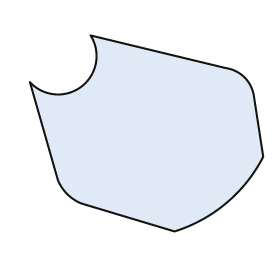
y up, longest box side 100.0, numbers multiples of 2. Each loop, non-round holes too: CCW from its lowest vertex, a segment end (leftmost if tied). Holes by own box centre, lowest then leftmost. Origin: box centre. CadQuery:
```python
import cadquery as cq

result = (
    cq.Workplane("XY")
    .moveTo(12.0, -42.0)
    .threePointArc((34.0, -30.0), (50.0, -10.0))
    .lineTo(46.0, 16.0)
    .threePointArc((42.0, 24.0), (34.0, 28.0))
    .lineTo(-24.0, 42.0)
    .threePointArc((-28.0, 20.0), (-50.0, 22.0))
    .lineTo(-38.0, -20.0)
    .threePointArc((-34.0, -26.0), (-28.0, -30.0))
    .close()
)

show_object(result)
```